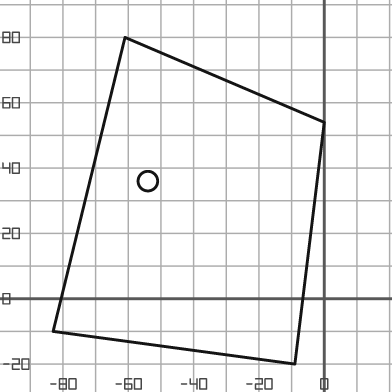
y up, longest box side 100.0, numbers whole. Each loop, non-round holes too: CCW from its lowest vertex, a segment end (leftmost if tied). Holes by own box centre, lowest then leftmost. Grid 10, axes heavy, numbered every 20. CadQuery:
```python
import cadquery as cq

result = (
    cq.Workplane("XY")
    .moveTo(-9.0, -20.0)
    .lineTo(0.0, 54.0)
    .lineTo(-61.0, 80.0)
    .lineTo(-83.0, -10.0)
    .close()
    .moveTo(-54.0, 36.0)
    .circle(3.0)
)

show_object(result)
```